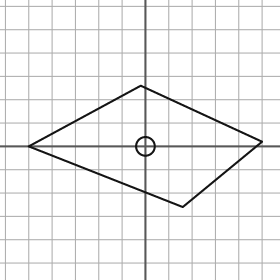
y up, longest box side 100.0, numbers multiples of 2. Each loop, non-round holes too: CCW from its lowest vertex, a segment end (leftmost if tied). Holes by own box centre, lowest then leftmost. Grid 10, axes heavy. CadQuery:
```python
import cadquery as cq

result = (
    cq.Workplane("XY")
    .moveTo(16.0, -26.0)
    .lineTo(50.0, 2.0)
    .lineTo(-2.0, 26.0)
    .lineTo(-50.0, 0.0)
    .close()
    .moveTo(0.0, 0.0)
    .circle(4.0)
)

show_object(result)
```